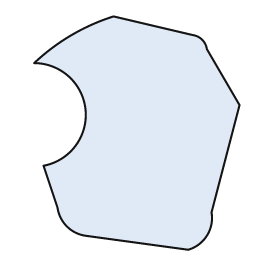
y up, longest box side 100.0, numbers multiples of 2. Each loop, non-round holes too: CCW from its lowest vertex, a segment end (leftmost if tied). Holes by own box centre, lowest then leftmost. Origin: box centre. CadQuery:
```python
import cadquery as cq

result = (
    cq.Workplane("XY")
    .moveTo(22.0, -50.0)
    .threePointArc((30.0, -44.0), (32.0, -34.0))
    .lineTo(44.0, 12.0)
    .lineTo(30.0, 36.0)
    .threePointArc((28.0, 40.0), (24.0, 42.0))
    .lineTo(-10.0, 50.0)
    .threePointArc((-28.0, 42.0), (-44.0, 30.0))
    .threePointArc((-22.0, 10.0), (-40.0, -14.0))
    .lineTo(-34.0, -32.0)
    .threePointArc((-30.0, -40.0), (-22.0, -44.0))
    .close()
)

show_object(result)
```